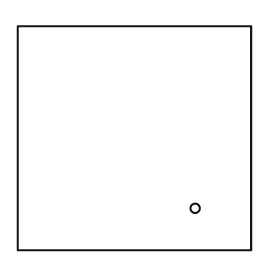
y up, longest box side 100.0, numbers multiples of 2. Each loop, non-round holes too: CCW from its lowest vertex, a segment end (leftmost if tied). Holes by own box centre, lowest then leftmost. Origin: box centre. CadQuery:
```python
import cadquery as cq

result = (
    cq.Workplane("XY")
    .moveTo(-50.0, -48.0)
    .lineTo(50.0, -48.0)
    .lineTo(50.0, 48.0)
    .lineTo(-50.0, 48.0)
    .close()
    .moveTo(26.0, -30.0)
    .circle(2.0)
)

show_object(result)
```